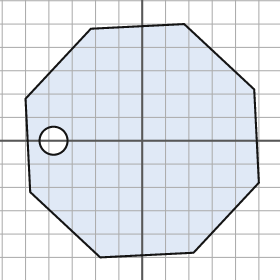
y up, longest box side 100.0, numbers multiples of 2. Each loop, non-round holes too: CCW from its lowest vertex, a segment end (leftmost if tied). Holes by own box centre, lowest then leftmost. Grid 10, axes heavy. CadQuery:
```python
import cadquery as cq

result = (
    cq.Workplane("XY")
    .moveTo(-18.0, -50.0)
    .lineTo(22.0, -48.0)
    .lineTo(50.0, -18.0)
    .lineTo(48.0, 22.0)
    .lineTo(18.0, 50.0)
    .lineTo(-22.0, 48.0)
    .lineTo(-50.0, 18.0)
    .lineTo(-48.0, -22.0)
    .close()
    .moveTo(-38.0, 0.0)
    .circle(6.0)
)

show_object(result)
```